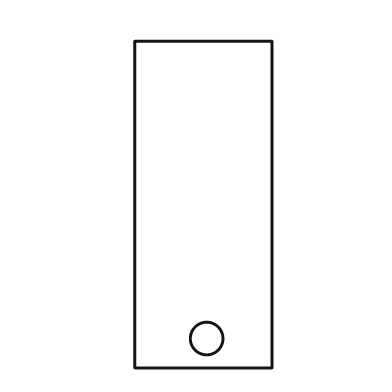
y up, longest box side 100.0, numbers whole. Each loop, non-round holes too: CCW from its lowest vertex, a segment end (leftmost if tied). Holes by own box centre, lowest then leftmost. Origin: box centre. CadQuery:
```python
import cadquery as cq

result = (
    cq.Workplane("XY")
    .moveTo(-21.0, -50.0)
    .lineTo(21.0, -50.0)
    .lineTo(21.0, 50.0)
    .lineTo(-21.0, 50.0)
    .close()
    .moveTo(1.0, -41.0)
    .circle(5.0)
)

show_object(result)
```